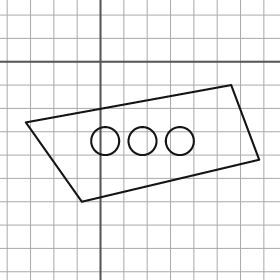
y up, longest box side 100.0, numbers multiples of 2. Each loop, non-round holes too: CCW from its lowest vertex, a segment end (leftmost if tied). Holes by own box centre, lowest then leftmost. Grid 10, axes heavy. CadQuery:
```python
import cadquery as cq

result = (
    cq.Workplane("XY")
    .moveTo(-8.0, -60.0)
    .lineTo(68.0, -42.0)
    .lineTo(56.0, -10.0)
    .lineTo(-32.0, -26.0)
    .close()
    .moveTo(2.0, -34.0)
    .circle(6.0)
    .moveTo(18.0, -34.0)
    .circle(6.0)
    .moveTo(34.0, -34.0)
    .circle(6.0)
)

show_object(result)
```